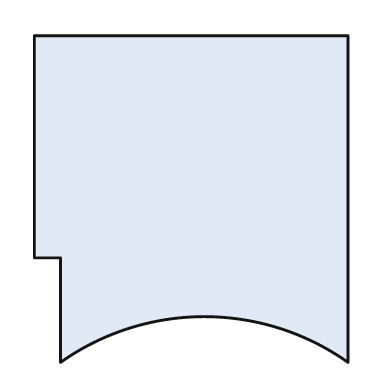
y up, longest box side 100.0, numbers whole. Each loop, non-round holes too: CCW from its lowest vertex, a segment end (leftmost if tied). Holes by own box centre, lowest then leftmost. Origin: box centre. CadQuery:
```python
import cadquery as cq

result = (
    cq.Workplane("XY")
    .moveTo(-40.0, -50.0)
    .threePointArc((4.0, -36.0), (48.0, -50.0))
    .lineTo(48.0, 50.0)
    .lineTo(-48.0, 50.0)
    .lineTo(-48.0, -18.0)
    .lineTo(-40.0, -18.0)
    .close()
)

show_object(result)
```